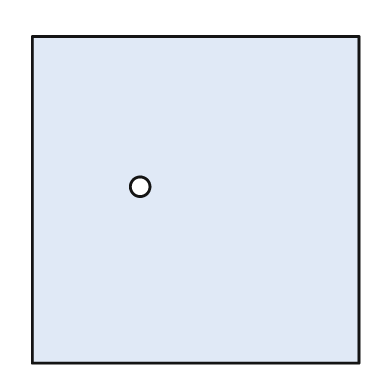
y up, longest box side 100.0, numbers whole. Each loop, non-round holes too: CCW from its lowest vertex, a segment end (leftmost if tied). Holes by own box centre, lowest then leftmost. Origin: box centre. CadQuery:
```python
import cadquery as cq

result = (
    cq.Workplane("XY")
    .moveTo(-50.0, -50.0)
    .lineTo(50.0, -50.0)
    .lineTo(50.0, 50.0)
    .lineTo(-50.0, 50.0)
    .close()
    .moveTo(-17.0, 4.0)
    .circle(3.0)
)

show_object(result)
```